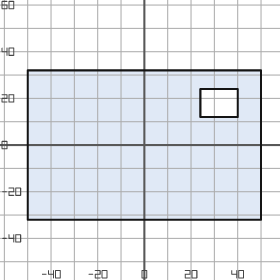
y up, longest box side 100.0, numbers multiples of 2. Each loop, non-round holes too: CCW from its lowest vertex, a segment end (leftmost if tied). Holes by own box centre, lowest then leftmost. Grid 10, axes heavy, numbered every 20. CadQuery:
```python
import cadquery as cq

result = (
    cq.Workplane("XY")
    .moveTo(-50.0, -32.0)
    .lineTo(50.0, -32.0)
    .lineTo(50.0, 32.0)
    .lineTo(-50.0, 32.0)
    .close()
    .moveTo(24.0, 12.0)
    .lineTo(40.0, 12.0)
    .lineTo(40.0, 24.0)
    .lineTo(24.0, 24.0)
    .close()
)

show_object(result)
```